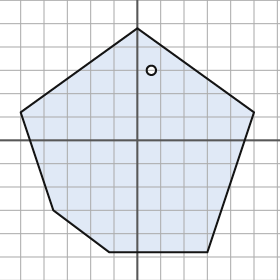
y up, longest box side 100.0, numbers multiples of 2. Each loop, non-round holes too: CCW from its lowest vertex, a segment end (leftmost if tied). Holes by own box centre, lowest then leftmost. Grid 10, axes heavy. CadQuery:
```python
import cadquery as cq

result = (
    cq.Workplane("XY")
    .moveTo(-12.0, -48.0)
    .lineTo(30.0, -48.0)
    .lineTo(50.0, 12.0)
    .lineTo(0.0, 48.0)
    .lineTo(-50.0, 12.0)
    .lineTo(-36.0, -30.0)
    .close()
    .moveTo(6.0, 30.0)
    .circle(2.0)
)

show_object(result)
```